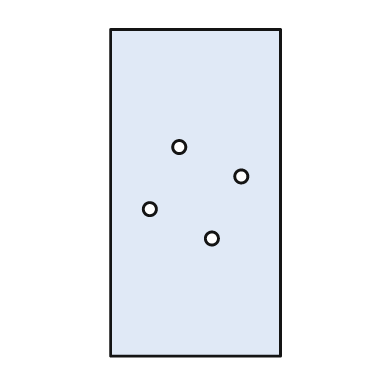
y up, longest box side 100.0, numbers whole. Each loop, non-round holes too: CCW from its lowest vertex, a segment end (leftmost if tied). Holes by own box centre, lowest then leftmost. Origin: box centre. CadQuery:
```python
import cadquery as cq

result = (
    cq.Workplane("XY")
    .moveTo(-26.0, -50.0)
    .lineTo(26.0, -50.0)
    .lineTo(26.0, 50.0)
    .lineTo(-26.0, 50.0)
    .close()
    .moveTo(5.0, -14.0)
    .circle(2.0)
    .moveTo(-14.0, -5.0)
    .circle(2.0)
    .moveTo(14.0, 5.0)
    .circle(2.0)
    .moveTo(-5.0, 14.0)
    .circle(2.0)
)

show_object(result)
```